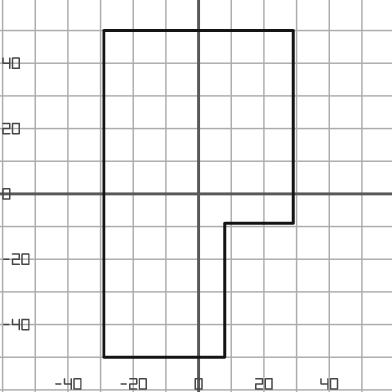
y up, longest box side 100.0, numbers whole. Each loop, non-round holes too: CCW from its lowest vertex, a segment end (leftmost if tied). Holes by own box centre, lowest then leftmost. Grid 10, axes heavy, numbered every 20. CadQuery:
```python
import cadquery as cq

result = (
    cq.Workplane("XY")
    .moveTo(-29.0, -50.0)
    .lineTo(8.0, -50.0)
    .lineTo(8.0, -9.0)
    .lineTo(29.0, -9.0)
    .lineTo(29.0, 50.0)
    .lineTo(-29.0, 50.0)
    .close()
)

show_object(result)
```